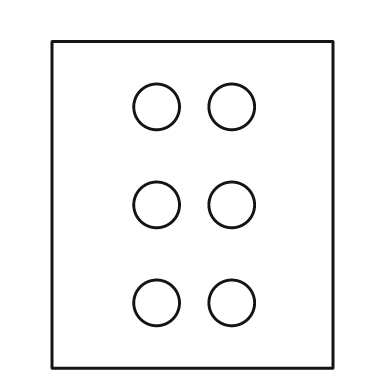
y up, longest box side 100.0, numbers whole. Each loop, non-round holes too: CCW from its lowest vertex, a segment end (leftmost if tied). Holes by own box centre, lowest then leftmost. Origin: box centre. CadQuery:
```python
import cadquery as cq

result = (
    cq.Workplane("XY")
    .moveTo(-43.0, -50.0)
    .lineTo(43.0, -50.0)
    .lineTo(43.0, 50.0)
    .lineTo(-43.0, 50.0)
    .close()
    .moveTo(-11.0, -30.0)
    .circle(7.0)
    .moveTo(12.0, -30.0)
    .circle(7.0)
    .moveTo(-11.0, 0.0)
    .circle(7.0)
    .moveTo(12.0, 0.0)
    .circle(7.0)
    .moveTo(-11.0, 30.0)
    .circle(7.0)
    .moveTo(12.0, 30.0)
    .circle(7.0)
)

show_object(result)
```